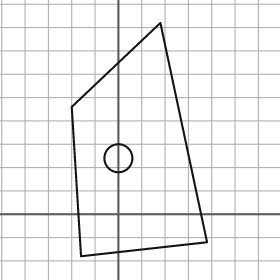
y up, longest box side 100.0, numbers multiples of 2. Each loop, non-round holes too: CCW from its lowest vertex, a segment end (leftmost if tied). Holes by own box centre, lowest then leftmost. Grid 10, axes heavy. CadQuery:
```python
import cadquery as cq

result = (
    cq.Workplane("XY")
    .moveTo(-16.0, -18.0)
    .lineTo(38.0, -12.0)
    .lineTo(18.0, 82.0)
    .lineTo(-20.0, 46.0)
    .close()
    .moveTo(0.0, 24.0)
    .circle(6.0)
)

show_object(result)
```